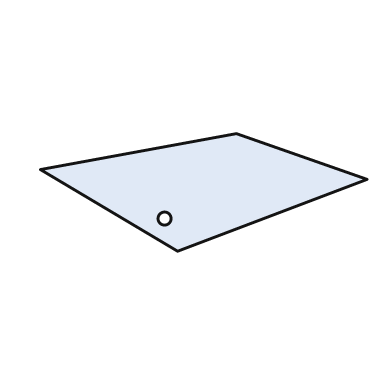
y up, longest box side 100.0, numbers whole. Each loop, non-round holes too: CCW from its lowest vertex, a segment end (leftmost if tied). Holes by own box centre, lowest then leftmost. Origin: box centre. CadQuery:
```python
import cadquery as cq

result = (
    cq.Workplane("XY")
    .moveTo(-8.0, -18.0)
    .lineTo(50.0, 4.0)
    .lineTo(10.0, 18.0)
    .lineTo(-50.0, 7.0)
    .close()
    .moveTo(-12.0, -8.0)
    .circle(2.0)
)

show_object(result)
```